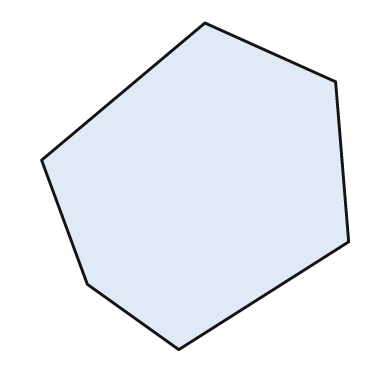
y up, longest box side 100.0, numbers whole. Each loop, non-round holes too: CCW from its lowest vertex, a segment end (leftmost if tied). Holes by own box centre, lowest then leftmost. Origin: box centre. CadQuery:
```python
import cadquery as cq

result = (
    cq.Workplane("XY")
    .moveTo(-5.0, -50.0)
    .lineTo(47.0, -17.0)
    .lineTo(43.0, 32.0)
    .lineTo(3.0, 50.0)
    .lineTo(-47.0, 8.0)
    .lineTo(-33.0, -30.0)
    .close()
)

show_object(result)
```